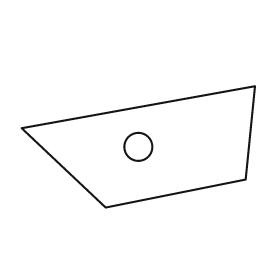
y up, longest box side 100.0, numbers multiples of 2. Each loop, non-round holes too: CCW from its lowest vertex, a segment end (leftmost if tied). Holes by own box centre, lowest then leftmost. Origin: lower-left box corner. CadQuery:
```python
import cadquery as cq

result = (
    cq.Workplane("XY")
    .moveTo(36.0, 0.0)
    .lineTo(96.0, 12.0)
    .lineTo(100.0, 52.0)
    .lineTo(0.0, 34.0)
    .close()
    .moveTo(50.0, 26.0)
    .circle(6.0)
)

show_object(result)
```